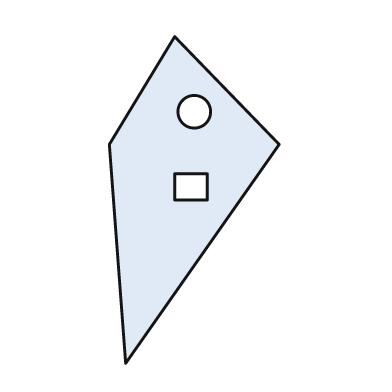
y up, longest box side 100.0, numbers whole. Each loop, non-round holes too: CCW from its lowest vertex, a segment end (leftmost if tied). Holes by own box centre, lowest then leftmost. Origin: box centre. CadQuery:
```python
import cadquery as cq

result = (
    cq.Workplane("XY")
    .moveTo(-21.0, -50.0)
    .lineTo(26.0, 17.0)
    .lineTo(-6.0, 50.0)
    .lineTo(-26.0, 17.0)
    .close()
    .moveTo(-6.0, 0.0)
    .lineTo(4.0, 0.0)
    .lineTo(4.0, 8.0)
    .lineTo(-6.0, 8.0)
    .close()
    .moveTo(0.0, 27.0)
    .circle(5.0)
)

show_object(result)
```